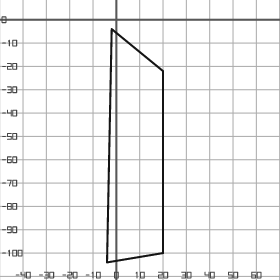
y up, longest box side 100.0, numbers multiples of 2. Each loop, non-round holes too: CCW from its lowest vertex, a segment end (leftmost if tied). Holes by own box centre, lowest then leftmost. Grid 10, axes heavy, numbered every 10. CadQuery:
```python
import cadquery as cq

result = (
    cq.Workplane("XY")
    .moveTo(-4.0, -104.0)
    .lineTo(20.0, -100.0)
    .lineTo(20.0, -22.0)
    .lineTo(-2.0, -4.0)
    .close()
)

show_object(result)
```